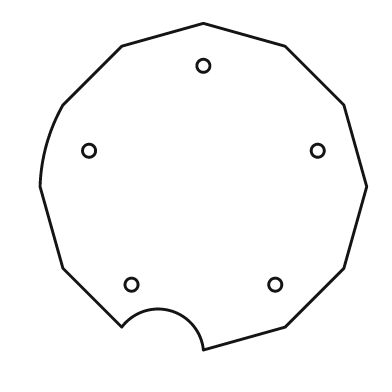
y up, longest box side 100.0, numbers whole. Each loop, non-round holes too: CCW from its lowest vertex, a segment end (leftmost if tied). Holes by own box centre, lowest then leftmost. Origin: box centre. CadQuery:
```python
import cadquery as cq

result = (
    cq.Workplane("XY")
    .moveTo(0.0, -50.0)
    .lineTo(25.0, -43.0)
    .lineTo(43.0, -25.0)
    .lineTo(50.0, 0.0)
    .lineTo(43.0, 25.0)
    .lineTo(25.0, 43.0)
    .lineTo(0.0, 50.0)
    .lineTo(-25.0, 43.0)
    .lineTo(-43.0, 25.0)
    .threePointArc((-48.0, 13.0), (-50.0, 0.0))
    .lineTo(-43.0, -25.0)
    .lineTo(-25.0, -43.0)
    .threePointArc((-10.0, -38.0), (0.0, -50.0))
    .close()
    .moveTo(-22.0, -30.0)
    .circle(2.0)
    .moveTo(22.0, -30.0)
    .circle(2.0)
    .moveTo(-35.0, 11.0)
    .circle(2.0)
    .moveTo(35.0, 11.0)
    .circle(2.0)
    .moveTo(0.0, 37.0)
    .circle(2.0)
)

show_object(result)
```